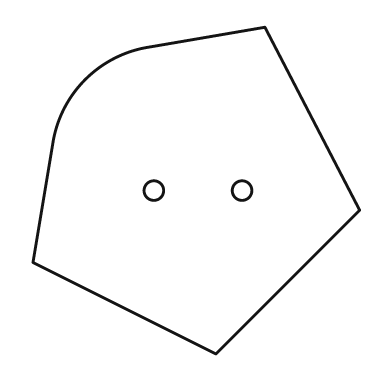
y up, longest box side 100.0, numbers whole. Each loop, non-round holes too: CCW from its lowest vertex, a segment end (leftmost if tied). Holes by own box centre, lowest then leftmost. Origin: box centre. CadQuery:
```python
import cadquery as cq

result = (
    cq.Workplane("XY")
    .moveTo(6.0, -50.0)
    .lineTo(50.0, -6.0)
    .lineTo(21.0, 50.0)
    .lineTo(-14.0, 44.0)
    .threePointArc((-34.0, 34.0), (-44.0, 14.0))
    .lineTo(-50.0, -22.0)
    .close()
    .moveTo(-13.0, 0.0)
    .circle(3.0)
    .moveTo(14.0, 0.0)
    .circle(3.0)
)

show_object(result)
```